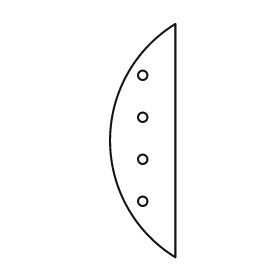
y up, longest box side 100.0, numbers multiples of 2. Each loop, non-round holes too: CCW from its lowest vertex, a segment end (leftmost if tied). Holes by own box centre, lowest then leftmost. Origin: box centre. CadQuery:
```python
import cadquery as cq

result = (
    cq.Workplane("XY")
    .moveTo(14.0, -50.0)
    .lineTo(14.0, 50.0)
    .threePointArc((-14.0, 0.0), (14.0, -50.0))
    .close()
    .moveTo(0.0, -26.0)
    .circle(2.0)
    .moveTo(0.0, -8.0)
    .circle(2.0)
    .moveTo(0.0, 10.0)
    .circle(2.0)
    .moveTo(0.0, 28.0)
    .circle(2.0)
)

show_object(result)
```